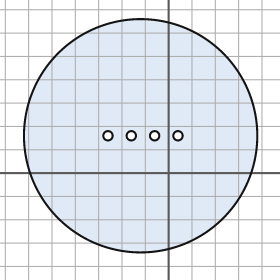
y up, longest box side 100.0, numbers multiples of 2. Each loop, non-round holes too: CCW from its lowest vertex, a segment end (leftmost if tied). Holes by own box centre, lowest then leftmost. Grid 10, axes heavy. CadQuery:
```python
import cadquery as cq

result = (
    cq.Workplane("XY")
    .moveTo(-12.0, 16.0)
    .circle(50.0)
    .moveTo(-26.0, 16.0)
    .circle(2.0)
    .moveTo(-16.0, 16.0)
    .circle(2.0)
    .moveTo(-6.0, 16.0)
    .circle(2.0)
    .moveTo(4.0, 16.0)
    .circle(2.0)
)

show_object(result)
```